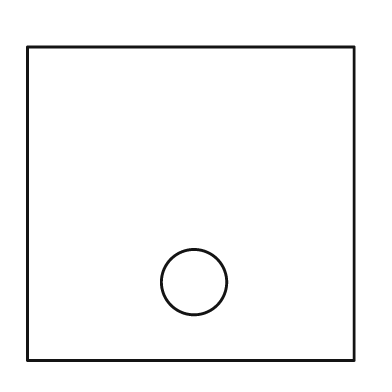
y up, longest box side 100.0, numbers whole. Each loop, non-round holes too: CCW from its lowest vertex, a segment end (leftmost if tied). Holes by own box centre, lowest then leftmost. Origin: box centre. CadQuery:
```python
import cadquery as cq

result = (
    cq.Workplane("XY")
    .moveTo(-50.0, -48.0)
    .lineTo(50.0, -48.0)
    .lineTo(50.0, 48.0)
    .lineTo(-50.0, 48.0)
    .close()
    .moveTo(1.0, -24.0)
    .circle(10.0)
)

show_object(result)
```